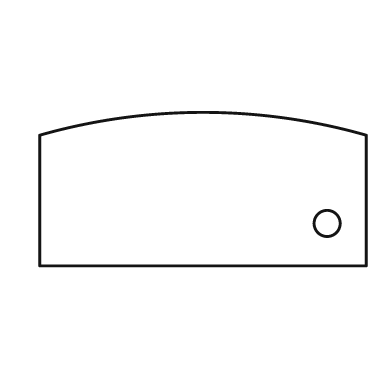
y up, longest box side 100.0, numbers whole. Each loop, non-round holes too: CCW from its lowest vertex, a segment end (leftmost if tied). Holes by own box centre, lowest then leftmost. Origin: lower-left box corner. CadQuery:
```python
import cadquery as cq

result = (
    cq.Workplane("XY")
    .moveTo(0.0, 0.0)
    .lineTo(100.0, 0.0)
    .lineTo(100.0, 40.0)
    .threePointArc((50.0, 47.0), (0.0, 40.0))
    .close()
    .moveTo(88.0, 13.0)
    .circle(4.0)
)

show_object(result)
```